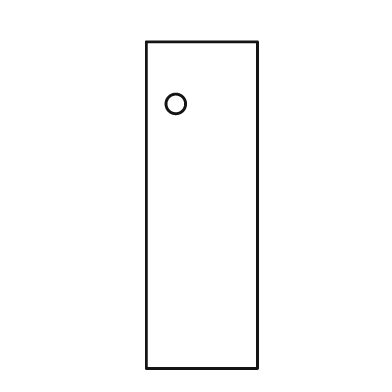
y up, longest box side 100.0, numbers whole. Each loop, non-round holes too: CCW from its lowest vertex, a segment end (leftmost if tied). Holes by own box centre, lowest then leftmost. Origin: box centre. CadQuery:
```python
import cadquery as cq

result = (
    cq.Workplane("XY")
    .moveTo(-17.0, -50.0)
    .lineTo(17.0, -50.0)
    .lineTo(17.0, 50.0)
    .lineTo(-17.0, 50.0)
    .close()
    .moveTo(-8.0, 31.0)
    .circle(3.0)
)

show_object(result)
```